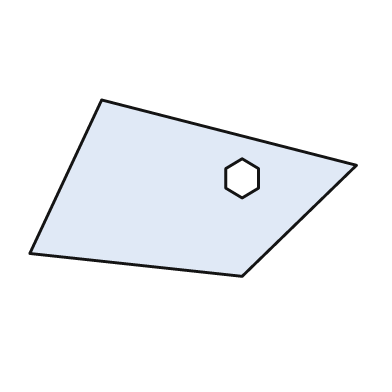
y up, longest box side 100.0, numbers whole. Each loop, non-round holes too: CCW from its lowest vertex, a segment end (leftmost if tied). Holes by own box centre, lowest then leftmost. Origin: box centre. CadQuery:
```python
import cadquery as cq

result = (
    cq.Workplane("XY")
    .moveTo(15.0, -27.0)
    .lineTo(50.0, 7.0)
    .lineTo(-28.0, 27.0)
    .lineTo(-50.0, -20.0)
    .close()
    .moveTo(15.0, -3.0)
    .lineTo(20.0, 0.0)
    .lineTo(20.0, 6.0)
    .lineTo(15.0, 9.0)
    .lineTo(10.0, 6.0)
    .lineTo(10.0, 0.0)
    .close()
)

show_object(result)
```